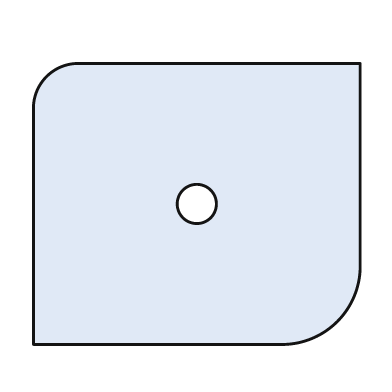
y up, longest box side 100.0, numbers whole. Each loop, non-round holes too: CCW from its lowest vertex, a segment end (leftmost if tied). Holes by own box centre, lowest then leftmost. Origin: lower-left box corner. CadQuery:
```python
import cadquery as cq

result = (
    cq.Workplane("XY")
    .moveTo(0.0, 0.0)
    .lineTo(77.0, 0.0)
    .threePointArc((93.0, 7.0), (100.0, 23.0))
    .lineTo(100.0, 86.0)
    .lineTo(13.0, 86.0)
    .threePointArc((4.0, 82.0), (0.0, 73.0))
    .close()
    .moveTo(50.0, 43.0)
    .circle(6.0)
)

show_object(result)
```